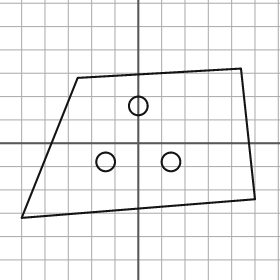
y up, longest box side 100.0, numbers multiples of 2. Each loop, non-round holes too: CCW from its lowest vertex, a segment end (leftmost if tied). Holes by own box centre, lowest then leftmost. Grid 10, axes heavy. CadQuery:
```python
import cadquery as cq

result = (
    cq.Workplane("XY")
    .moveTo(-50.0, -32.0)
    .lineTo(50.0, -24.0)
    .lineTo(44.0, 32.0)
    .lineTo(-26.0, 28.0)
    .close()
    .moveTo(-14.0, -8.0)
    .circle(4.0)
    .moveTo(14.0, -8.0)
    .circle(4.0)
    .moveTo(0.0, 16.0)
    .circle(4.0)
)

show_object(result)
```